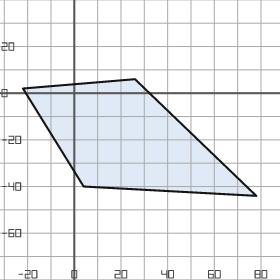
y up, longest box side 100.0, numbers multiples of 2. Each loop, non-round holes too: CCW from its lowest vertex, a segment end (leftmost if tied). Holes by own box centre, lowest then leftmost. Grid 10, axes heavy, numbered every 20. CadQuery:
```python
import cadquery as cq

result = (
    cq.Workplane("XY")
    .moveTo(78.0, -44.0)
    .lineTo(26.0, 6.0)
    .lineTo(-22.0, 2.0)
    .lineTo(4.0, -40.0)
    .close()
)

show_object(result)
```